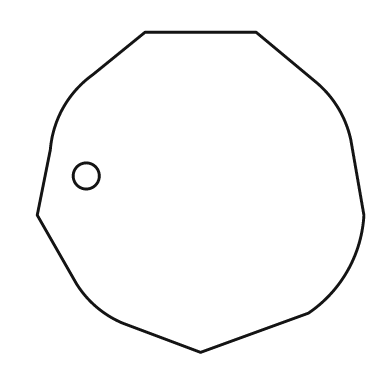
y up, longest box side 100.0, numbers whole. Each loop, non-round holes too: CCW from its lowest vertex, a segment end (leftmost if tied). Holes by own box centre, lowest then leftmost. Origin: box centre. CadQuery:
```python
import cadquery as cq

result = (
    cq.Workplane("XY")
    .moveTo(0.0, -49.0)
    .lineTo(33.0, -37.0)
    .threePointArc((45.0, -24.0), (50.0, -7.0))
    .lineTo(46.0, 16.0)
    .threePointArc((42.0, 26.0), (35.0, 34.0))
    .lineTo(17.0, 49.0)
    .lineTo(-17.0, 49.0)
    .lineTo(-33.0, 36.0)
    .threePointArc((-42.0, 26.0), (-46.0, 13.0))
    .lineTo(-50.0, -7.0)
    .lineTo(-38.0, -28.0)
    .threePointArc((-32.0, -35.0), (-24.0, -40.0))
    .close()
    .moveTo(-35.0, 5.0)
    .circle(4.0)
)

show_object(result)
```